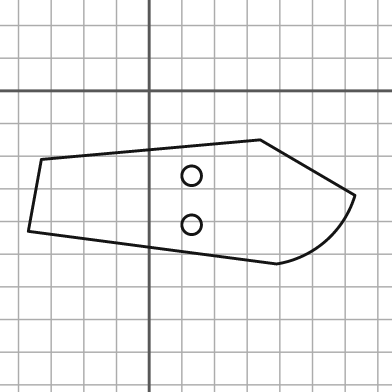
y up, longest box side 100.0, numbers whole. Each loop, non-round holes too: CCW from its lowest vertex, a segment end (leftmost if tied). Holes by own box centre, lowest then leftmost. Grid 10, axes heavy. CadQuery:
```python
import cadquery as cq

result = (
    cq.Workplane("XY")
    .moveTo(39.0, -53.0)
    .threePointArc((54.0, -46.0), (63.0, -32.0))
    .lineTo(34.0, -15.0)
    .lineTo(-33.0, -21.0)
    .lineTo(-37.0, -43.0)
    .close()
    .moveTo(13.0, -41.0)
    .circle(3.0)
    .moveTo(13.0, -26.0)
    .circle(3.0)
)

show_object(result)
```